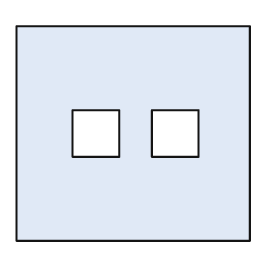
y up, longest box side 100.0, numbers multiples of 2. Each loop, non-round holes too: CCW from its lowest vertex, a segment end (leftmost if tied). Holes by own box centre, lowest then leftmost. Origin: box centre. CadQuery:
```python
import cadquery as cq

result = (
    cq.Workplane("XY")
    .moveTo(-50.0, -46.0)
    .lineTo(50.0, -46.0)
    .lineTo(50.0, 46.0)
    .lineTo(-50.0, 46.0)
    .close()
    .moveTo(-26.0, -10.0)
    .lineTo(-6.0, -10.0)
    .lineTo(-6.0, 10.0)
    .lineTo(-26.0, 10.0)
    .close()
    .moveTo(8.0, -10.0)
    .lineTo(28.0, -10.0)
    .lineTo(28.0, 10.0)
    .lineTo(8.0, 10.0)
    .close()
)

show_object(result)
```